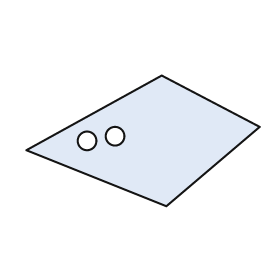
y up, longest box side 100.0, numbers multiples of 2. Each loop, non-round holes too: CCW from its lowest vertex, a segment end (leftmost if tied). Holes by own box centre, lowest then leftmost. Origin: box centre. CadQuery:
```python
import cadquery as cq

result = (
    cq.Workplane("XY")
    .moveTo(10.0, -28.0)
    .lineTo(50.0, 6.0)
    .lineTo(8.0, 28.0)
    .lineTo(-50.0, -4.0)
    .close()
    .moveTo(-24.0, 0.0)
    .circle(4.0)
    .moveTo(-12.0, 2.0)
    .circle(4.0)
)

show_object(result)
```